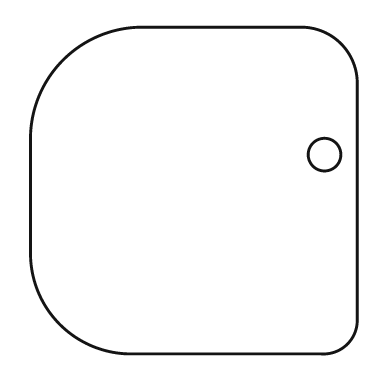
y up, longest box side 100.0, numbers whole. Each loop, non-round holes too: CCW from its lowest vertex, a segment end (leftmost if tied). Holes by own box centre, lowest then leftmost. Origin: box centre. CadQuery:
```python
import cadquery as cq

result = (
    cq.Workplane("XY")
    .moveTo(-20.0, -50.0)
    .lineTo(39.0, -50.0)
    .threePointArc((47.0, -47.0), (50.0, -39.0))
    .lineTo(50.0, 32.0)
    .threePointArc((45.0, 45.0), (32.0, 50.0))
    .lineTo(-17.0, 50.0)
    .threePointArc((-40.0, 40.0), (-50.0, 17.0))
    .lineTo(-50.0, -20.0)
    .threePointArc((-41.0, -41.0), (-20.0, -50.0))
    .close()
    .moveTo(40.0, 11.0)
    .circle(5.0)
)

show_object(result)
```